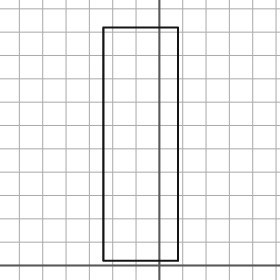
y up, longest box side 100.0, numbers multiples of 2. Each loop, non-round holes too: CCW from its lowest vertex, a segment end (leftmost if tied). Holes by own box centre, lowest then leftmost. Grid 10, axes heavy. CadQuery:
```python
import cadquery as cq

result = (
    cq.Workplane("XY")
    .moveTo(-24.0, 2.0)
    .lineTo(8.0, 2.0)
    .lineTo(8.0, 102.0)
    .lineTo(-24.0, 102.0)
    .close()
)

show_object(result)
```